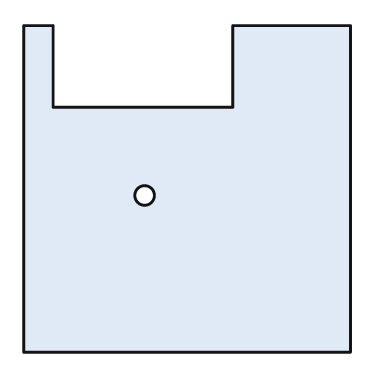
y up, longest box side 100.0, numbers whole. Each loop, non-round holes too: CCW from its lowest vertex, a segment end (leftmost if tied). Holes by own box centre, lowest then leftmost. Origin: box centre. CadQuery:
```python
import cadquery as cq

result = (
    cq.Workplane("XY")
    .moveTo(-50.0, -50.0)
    .lineTo(50.0, -50.0)
    .lineTo(50.0, 50.0)
    .lineTo(14.0, 50.0)
    .lineTo(14.0, 25.0)
    .lineTo(-41.0, 25.0)
    .lineTo(-41.0, 50.0)
    .lineTo(-50.0, 50.0)
    .close()
    .moveTo(-13.0, -2.0)
    .circle(3.0)
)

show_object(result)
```